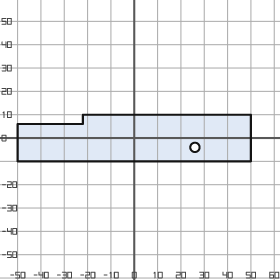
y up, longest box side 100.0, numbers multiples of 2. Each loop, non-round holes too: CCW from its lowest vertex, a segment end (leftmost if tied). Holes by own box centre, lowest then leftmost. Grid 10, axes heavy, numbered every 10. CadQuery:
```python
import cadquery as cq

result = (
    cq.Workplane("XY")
    .moveTo(-50.0, -10.0)
    .lineTo(50.0, -10.0)
    .lineTo(50.0, 10.0)
    .lineTo(-22.0, 10.0)
    .lineTo(-22.0, 6.0)
    .lineTo(-50.0, 6.0)
    .close()
    .moveTo(26.0, -4.0)
    .circle(2.0)
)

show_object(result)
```